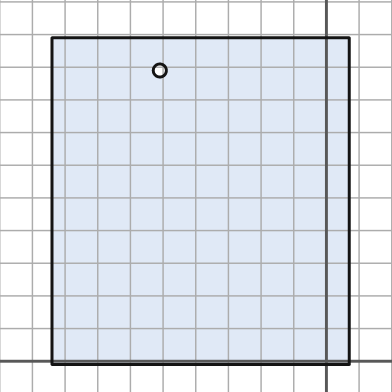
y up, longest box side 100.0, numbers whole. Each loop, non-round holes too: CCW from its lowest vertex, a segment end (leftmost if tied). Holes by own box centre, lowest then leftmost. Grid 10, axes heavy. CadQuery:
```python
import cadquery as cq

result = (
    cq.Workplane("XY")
    .moveTo(-84.0, -1.0)
    .lineTo(7.0, -1.0)
    .lineTo(7.0, 99.0)
    .lineTo(-84.0, 99.0)
    .close()
    .moveTo(-51.0, 89.0)
    .circle(2.0)
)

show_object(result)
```